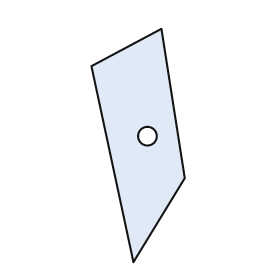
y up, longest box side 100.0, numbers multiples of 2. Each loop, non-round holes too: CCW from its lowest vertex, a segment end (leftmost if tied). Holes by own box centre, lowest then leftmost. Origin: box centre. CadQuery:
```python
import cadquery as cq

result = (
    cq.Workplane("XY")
    .moveTo(-2.0, -50.0)
    .lineTo(20.0, -14.0)
    .lineTo(10.0, 50.0)
    .lineTo(-20.0, 34.0)
    .close()
    .moveTo(4.0, 4.0)
    .circle(4.0)
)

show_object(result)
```